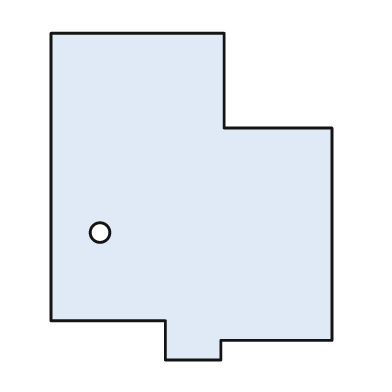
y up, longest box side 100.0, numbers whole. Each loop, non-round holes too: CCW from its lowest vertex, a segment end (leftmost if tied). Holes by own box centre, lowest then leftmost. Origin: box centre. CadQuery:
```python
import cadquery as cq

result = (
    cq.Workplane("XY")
    .moveTo(-8.0, -50.0)
    .lineTo(9.0, -50.0)
    .lineTo(9.0, -44.0)
    .lineTo(43.0, -44.0)
    .lineTo(43.0, 21.0)
    .lineTo(10.0, 21.0)
    .lineTo(10.0, 50.0)
    .lineTo(-43.0, 50.0)
    .lineTo(-43.0, -38.0)
    .lineTo(-8.0, -38.0)
    .close()
    .moveTo(-28.0, -11.0)
    .circle(3.0)
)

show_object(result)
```